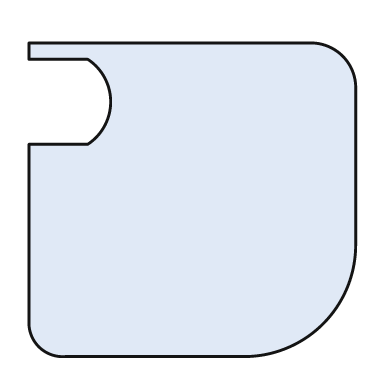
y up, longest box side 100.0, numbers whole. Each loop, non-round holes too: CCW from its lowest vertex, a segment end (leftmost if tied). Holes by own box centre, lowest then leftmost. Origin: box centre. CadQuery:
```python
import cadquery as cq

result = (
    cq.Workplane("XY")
    .moveTo(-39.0, -48.0)
    .lineTo(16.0, -48.0)
    .threePointArc((40.0, -38.0), (50.0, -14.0))
    .lineTo(50.0, 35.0)
    .threePointArc((46.0, 44.0), (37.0, 48.0))
    .lineTo(-50.0, 48.0)
    .lineTo(-50.0, 43.0)
    .lineTo(-32.0, 43.0)
    .threePointArc((-25.0, 30.0), (-32.0, 17.0))
    .lineTo(-50.0, 17.0)
    .lineTo(-50.0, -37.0)
    .threePointArc((-47.0, -45.0), (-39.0, -48.0))
    .close()
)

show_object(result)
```